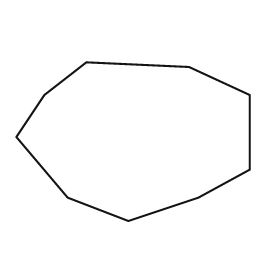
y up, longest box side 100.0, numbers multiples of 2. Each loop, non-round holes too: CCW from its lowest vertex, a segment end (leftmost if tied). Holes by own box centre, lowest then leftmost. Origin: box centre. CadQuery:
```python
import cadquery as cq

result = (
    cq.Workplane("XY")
    .moveTo(-2.0, -34.0)
    .lineTo(28.0, -24.0)
    .lineTo(50.0, -12.0)
    .lineTo(50.0, 20.0)
    .lineTo(24.0, 32.0)
    .lineTo(-20.0, 34.0)
    .lineTo(-38.0, 20.0)
    .lineTo(-50.0, 2.0)
    .lineTo(-28.0, -24.0)
    .close()
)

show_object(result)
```